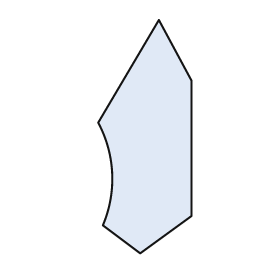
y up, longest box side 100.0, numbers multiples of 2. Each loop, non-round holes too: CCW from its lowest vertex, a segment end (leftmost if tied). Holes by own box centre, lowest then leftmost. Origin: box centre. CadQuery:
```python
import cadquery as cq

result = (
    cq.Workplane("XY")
    .moveTo(-2.0, -50.0)
    .lineTo(20.0, -34.0)
    .lineTo(20.0, 24.0)
    .lineTo(6.0, 50.0)
    .lineTo(-20.0, 6.0)
    .threePointArc((-14.0, -16.0), (-18.0, -38.0))
    .close()
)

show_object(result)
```